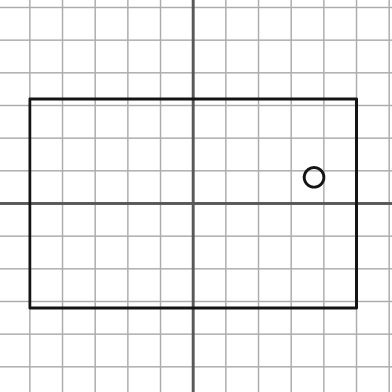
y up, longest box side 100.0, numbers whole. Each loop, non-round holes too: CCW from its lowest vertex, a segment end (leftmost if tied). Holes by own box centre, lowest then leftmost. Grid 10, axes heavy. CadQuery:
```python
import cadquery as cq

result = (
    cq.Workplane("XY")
    .moveTo(-50.0, -32.0)
    .lineTo(50.0, -32.0)
    .lineTo(50.0, 32.0)
    .lineTo(-50.0, 32.0)
    .close()
    .moveTo(37.0, 8.0)
    .circle(3.0)
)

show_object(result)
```